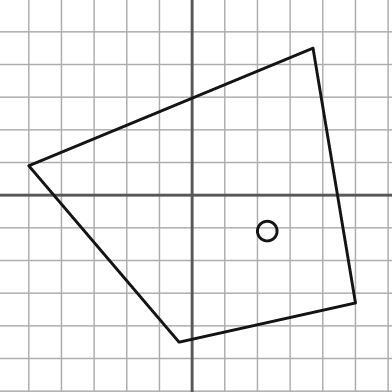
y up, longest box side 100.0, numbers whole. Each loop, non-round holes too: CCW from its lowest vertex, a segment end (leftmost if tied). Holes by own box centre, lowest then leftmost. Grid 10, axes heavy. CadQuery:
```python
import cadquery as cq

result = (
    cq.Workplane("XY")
    .moveTo(-4.0, -45.0)
    .lineTo(50.0, -33.0)
    .lineTo(37.0, 45.0)
    .lineTo(-50.0, 9.0)
    .close()
    .moveTo(23.0, -11.0)
    .circle(3.0)
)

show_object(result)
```